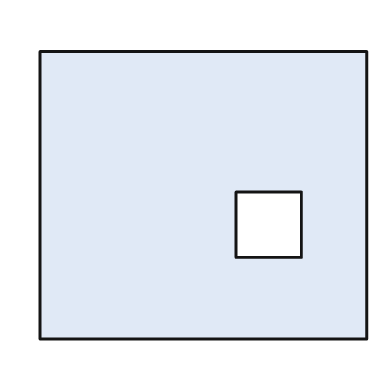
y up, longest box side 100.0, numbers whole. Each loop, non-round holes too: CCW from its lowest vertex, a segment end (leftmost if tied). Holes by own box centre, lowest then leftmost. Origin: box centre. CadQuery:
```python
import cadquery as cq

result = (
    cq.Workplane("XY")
    .moveTo(-50.0, -44.0)
    .lineTo(50.0, -44.0)
    .lineTo(50.0, 44.0)
    .lineTo(-50.0, 44.0)
    .close()
    .moveTo(10.0, -19.0)
    .lineTo(30.0, -19.0)
    .lineTo(30.0, 1.0)
    .lineTo(10.0, 1.0)
    .close()
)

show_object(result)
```